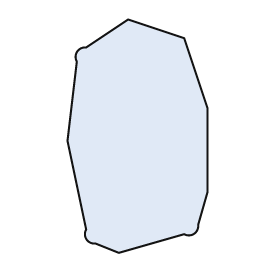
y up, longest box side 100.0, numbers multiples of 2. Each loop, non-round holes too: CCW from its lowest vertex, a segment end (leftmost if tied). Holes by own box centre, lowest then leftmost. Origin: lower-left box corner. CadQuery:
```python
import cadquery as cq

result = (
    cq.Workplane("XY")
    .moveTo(22.0, 0.0)
    .lineTo(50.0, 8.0)
    .threePointArc((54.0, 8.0), (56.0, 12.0))
    .lineTo(60.0, 26.0)
    .lineTo(60.0, 62.0)
    .lineTo(50.0, 92.0)
    .lineTo(26.0, 100.0)
    .lineTo(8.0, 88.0)
    .threePointArc((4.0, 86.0), (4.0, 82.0))
    .lineTo(0.0, 48.0)
    .lineTo(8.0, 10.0)
    .threePointArc((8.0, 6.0), (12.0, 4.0))
    .close()
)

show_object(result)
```